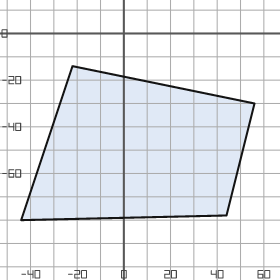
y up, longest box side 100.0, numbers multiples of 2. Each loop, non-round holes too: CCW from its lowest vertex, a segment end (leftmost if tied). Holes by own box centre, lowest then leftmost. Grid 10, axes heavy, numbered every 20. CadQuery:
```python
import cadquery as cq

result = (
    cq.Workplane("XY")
    .moveTo(-44.0, -80.0)
    .lineTo(44.0, -78.0)
    .lineTo(56.0, -30.0)
    .lineTo(-22.0, -14.0)
    .close()
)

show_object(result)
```